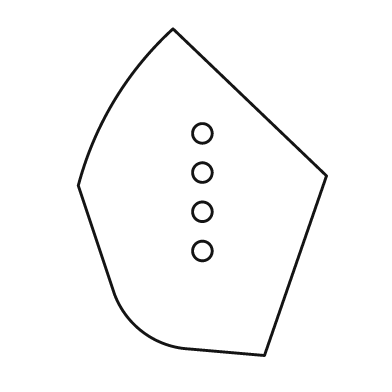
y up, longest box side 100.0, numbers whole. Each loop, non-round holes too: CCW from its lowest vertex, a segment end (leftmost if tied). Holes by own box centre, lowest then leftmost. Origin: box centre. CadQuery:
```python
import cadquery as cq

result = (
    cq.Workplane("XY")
    .moveTo(19.0, -50.0)
    .lineTo(38.0, 5.0)
    .lineTo(-9.0, 50.0)
    .threePointArc((-27.0, 28.0), (-38.0, 2.0))
    .lineTo(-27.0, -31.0)
    .threePointArc((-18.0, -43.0), (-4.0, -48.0))
    .close()
    .moveTo(0.0, -18.0)
    .circle(3.0)
    .moveTo(0.0, -6.0)
    .circle(3.0)
    .moveTo(0.0, 6.0)
    .circle(3.0)
    .moveTo(0.0, 18.0)
    .circle(3.0)
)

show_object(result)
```